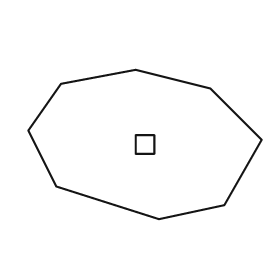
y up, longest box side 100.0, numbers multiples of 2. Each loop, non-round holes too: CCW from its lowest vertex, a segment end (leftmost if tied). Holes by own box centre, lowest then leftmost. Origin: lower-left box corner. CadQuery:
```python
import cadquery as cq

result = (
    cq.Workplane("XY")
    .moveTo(56.0, 0.0)
    .lineTo(84.0, 6.0)
    .lineTo(100.0, 34.0)
    .lineTo(78.0, 56.0)
    .lineTo(46.0, 64.0)
    .lineTo(14.0, 58.0)
    .lineTo(0.0, 38.0)
    .lineTo(12.0, 14.0)
    .close()
    .moveTo(46.0, 28.0)
    .lineTo(54.0, 28.0)
    .lineTo(54.0, 36.0)
    .lineTo(46.0, 36.0)
    .close()
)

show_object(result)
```